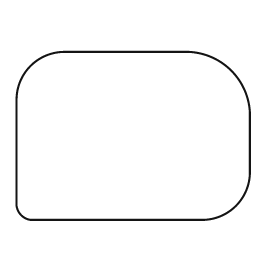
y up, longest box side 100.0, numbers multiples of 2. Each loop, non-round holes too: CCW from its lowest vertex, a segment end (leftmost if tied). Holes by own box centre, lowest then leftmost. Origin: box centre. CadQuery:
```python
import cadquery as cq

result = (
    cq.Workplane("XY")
    .moveTo(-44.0, -36.0)
    .lineTo(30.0, -36.0)
    .threePointArc((44.0, -30.0), (50.0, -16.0))
    .lineTo(50.0, 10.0)
    .threePointArc((42.0, 28.0), (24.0, 36.0))
    .lineTo(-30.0, 36.0)
    .threePointArc((-44.0, 30.0), (-50.0, 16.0))
    .lineTo(-50.0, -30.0)
    .threePointArc((-48.0, -34.0), (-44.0, -36.0))
    .close()
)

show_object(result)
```